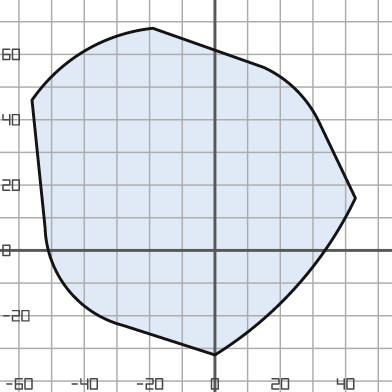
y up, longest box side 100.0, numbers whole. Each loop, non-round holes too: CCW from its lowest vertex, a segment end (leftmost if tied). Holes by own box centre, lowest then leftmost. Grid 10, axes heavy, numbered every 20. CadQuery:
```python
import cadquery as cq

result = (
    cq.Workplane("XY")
    .moveTo(0.0, -32.0)
    .threePointArc((25.0, -11.0), (43.0, 16.0))
    .lineTo(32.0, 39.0)
    .threePointArc((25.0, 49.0), (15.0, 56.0))
    .lineTo(-19.0, 68.0)
    .threePointArc((-40.0, 61.0), (-56.0, 46.0))
    .lineTo(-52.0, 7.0)
    .threePointArc((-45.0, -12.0), (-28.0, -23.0))
    .close()
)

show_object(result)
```